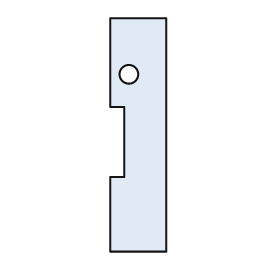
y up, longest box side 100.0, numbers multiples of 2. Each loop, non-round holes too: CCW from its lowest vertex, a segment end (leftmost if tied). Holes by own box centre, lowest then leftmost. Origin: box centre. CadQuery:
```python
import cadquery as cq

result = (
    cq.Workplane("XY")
    .moveTo(-12.0, -50.0)
    .lineTo(12.0, -50.0)
    .lineTo(12.0, 50.0)
    .lineTo(-12.0, 50.0)
    .lineTo(-12.0, 12.0)
    .lineTo(-6.0, 12.0)
    .lineTo(-6.0, -18.0)
    .lineTo(-12.0, -18.0)
    .close()
    .moveTo(-4.0, 26.0)
    .circle(4.0)
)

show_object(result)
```